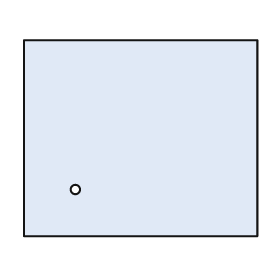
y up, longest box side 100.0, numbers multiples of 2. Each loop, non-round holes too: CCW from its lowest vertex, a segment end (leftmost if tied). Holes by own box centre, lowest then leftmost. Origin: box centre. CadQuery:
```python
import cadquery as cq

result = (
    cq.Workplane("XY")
    .moveTo(-50.0, -42.0)
    .lineTo(50.0, -42.0)
    .lineTo(50.0, 42.0)
    .lineTo(-50.0, 42.0)
    .close()
    .moveTo(-28.0, -22.0)
    .circle(2.0)
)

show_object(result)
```